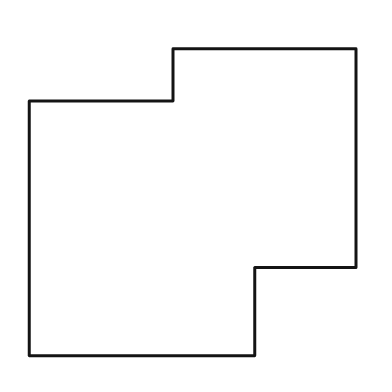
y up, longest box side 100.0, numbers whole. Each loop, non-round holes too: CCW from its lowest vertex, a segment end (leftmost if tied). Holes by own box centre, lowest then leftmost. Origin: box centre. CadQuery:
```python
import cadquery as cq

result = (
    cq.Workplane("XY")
    .moveTo(-50.0, -47.0)
    .lineTo(19.0, -47.0)
    .lineTo(19.0, -20.0)
    .lineTo(50.0, -20.0)
    .lineTo(50.0, 47.0)
    .lineTo(-6.0, 47.0)
    .lineTo(-6.0, 31.0)
    .lineTo(-50.0, 31.0)
    .close()
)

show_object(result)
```